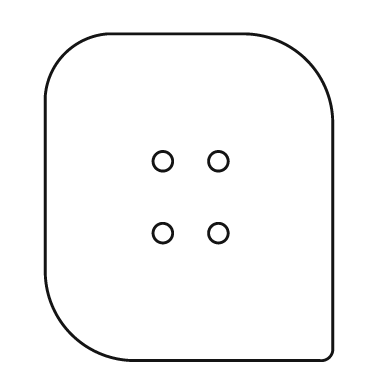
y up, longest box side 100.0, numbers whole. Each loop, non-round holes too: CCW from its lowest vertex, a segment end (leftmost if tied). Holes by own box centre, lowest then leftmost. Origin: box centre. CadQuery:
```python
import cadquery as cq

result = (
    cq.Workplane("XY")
    .moveTo(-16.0, -50.0)
    .lineTo(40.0, -50.0)
    .threePointArc((43.0, -49.0), (44.0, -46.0))
    .lineTo(44.0, 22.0)
    .threePointArc((36.0, 42.0), (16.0, 50.0))
    .lineTo(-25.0, 50.0)
    .threePointArc((-38.0, 44.0), (-44.0, 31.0))
    .lineTo(-44.0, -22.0)
    .threePointArc((-36.0, -42.0), (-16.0, -50.0))
    .close()
    .moveTo(-8.0, -11.0)
    .circle(3.0)
    .moveTo(9.0, -11.0)
    .circle(3.0)
    .moveTo(-8.0, 11.0)
    .circle(3.0)
    .moveTo(9.0, 11.0)
    .circle(3.0)
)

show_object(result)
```